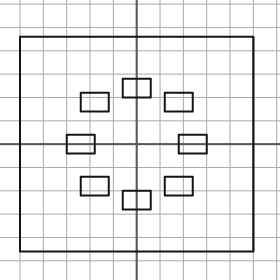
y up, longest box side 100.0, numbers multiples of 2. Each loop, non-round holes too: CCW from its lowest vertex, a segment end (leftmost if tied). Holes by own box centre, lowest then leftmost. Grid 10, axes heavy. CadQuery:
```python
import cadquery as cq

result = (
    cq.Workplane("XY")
    .moveTo(-50.0, -46.0)
    .lineTo(50.0, -46.0)
    .lineTo(50.0, 46.0)
    .lineTo(-50.0, 46.0)
    .close()
    .moveTo(-6.0, -28.0)
    .lineTo(6.0, -28.0)
    .lineTo(6.0, -20.0)
    .lineTo(-6.0, -20.0)
    .close()
    .moveTo(-24.0, -22.0)
    .lineTo(-12.0, -22.0)
    .lineTo(-12.0, -14.0)
    .lineTo(-24.0, -14.0)
    .close()
    .moveTo(12.0, -22.0)
    .lineTo(24.0, -22.0)
    .lineTo(24.0, -14.0)
    .lineTo(12.0, -14.0)
    .close()
    .moveTo(-30.0, -4.0)
    .lineTo(-18.0, -4.0)
    .lineTo(-18.0, 4.0)
    .lineTo(-30.0, 4.0)
    .close()
    .moveTo(18.0, -4.0)
    .lineTo(30.0, -4.0)
    .lineTo(30.0, 4.0)
    .lineTo(18.0, 4.0)
    .close()
    .moveTo(-24.0, 14.0)
    .lineTo(-12.0, 14.0)
    .lineTo(-12.0, 22.0)
    .lineTo(-24.0, 22.0)
    .close()
    .moveTo(12.0, 14.0)
    .lineTo(24.0, 14.0)
    .lineTo(24.0, 22.0)
    .lineTo(12.0, 22.0)
    .close()
    .moveTo(-6.0, 20.0)
    .lineTo(6.0, 20.0)
    .lineTo(6.0, 28.0)
    .lineTo(-6.0, 28.0)
    .close()
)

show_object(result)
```